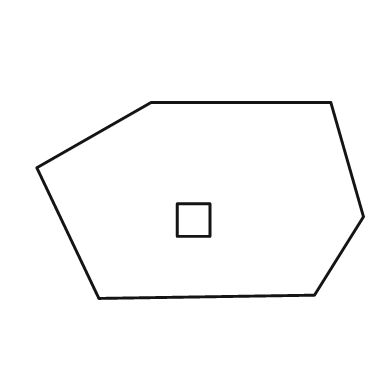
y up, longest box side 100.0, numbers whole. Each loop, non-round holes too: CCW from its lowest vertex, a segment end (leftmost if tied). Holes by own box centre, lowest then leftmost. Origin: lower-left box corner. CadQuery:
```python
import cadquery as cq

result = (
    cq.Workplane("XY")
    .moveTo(19.0, 0.0)
    .lineTo(85.0, 1.0)
    .lineTo(100.0, 25.0)
    .lineTo(90.0, 60.0)
    .lineTo(35.0, 60.0)
    .lineTo(0.0, 40.0)
    .close()
    .moveTo(43.0, 19.0)
    .lineTo(53.0, 19.0)
    .lineTo(53.0, 29.0)
    .lineTo(43.0, 29.0)
    .close()
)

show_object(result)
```